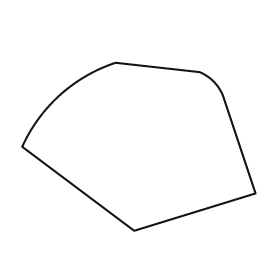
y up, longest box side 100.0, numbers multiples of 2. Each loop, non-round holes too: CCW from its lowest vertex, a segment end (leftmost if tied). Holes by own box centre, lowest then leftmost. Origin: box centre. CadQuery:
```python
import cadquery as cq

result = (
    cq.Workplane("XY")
    .moveTo(-2.0, -36.0)
    .lineTo(50.0, -20.0)
    .lineTo(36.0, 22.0)
    .threePointArc((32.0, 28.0), (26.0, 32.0))
    .lineTo(-10.0, 36.0)
    .threePointArc((-34.0, 22.0), (-50.0, 0.0))
    .close()
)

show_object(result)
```